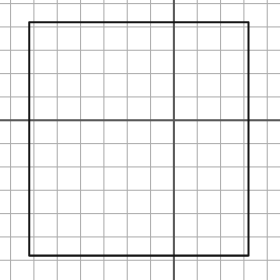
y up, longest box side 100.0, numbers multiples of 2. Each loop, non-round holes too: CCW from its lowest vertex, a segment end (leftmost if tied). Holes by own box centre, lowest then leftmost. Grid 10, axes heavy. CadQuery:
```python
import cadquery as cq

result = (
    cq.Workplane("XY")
    .moveTo(-62.0, -58.0)
    .lineTo(32.0, -58.0)
    .lineTo(32.0, 42.0)
    .lineTo(-62.0, 42.0)
    .close()
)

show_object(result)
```